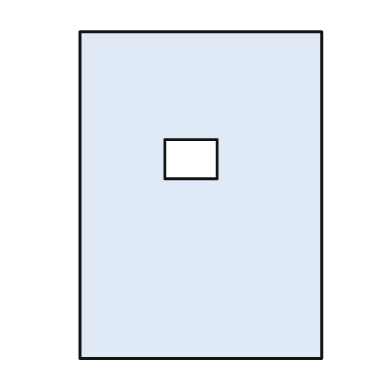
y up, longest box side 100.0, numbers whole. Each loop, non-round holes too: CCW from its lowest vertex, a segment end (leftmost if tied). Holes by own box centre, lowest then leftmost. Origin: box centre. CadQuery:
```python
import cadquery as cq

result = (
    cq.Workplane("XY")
    .moveTo(-37.0, -50.0)
    .lineTo(37.0, -50.0)
    .lineTo(37.0, 50.0)
    .lineTo(-37.0, 50.0)
    .close()
    .moveTo(-11.0, 5.0)
    .lineTo(5.0, 5.0)
    .lineTo(5.0, 17.0)
    .lineTo(-11.0, 17.0)
    .close()
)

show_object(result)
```